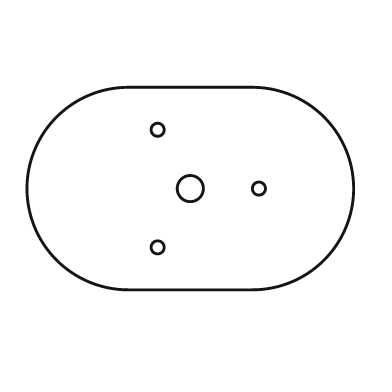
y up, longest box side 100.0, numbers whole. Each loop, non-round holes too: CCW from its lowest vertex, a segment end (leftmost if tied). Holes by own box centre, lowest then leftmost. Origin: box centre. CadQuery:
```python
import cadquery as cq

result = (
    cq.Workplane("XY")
    .moveTo(-19.0, -31.0)
    .lineTo(19.0, -31.0)
    .threePointArc((50.0, 0.0), (19.0, 31.0))
    .lineTo(-19.0, 31.0)
    .threePointArc((-50.0, 0.0), (-19.0, -31.0))
    .close()
    .moveTo(-10.0, -18.0)
    .circle(2.0)
    .moveTo(0.0, 0.0)
    .circle(4.0)
    .moveTo(21.0, 0.0)
    .circle(2.0)
    .moveTo(-10.0, 18.0)
    .circle(2.0)
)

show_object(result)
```